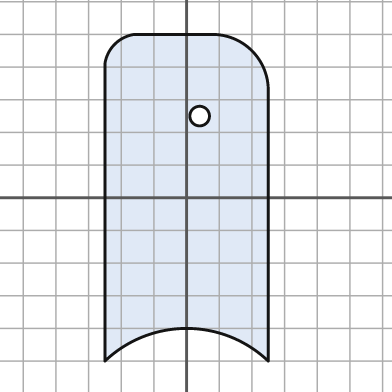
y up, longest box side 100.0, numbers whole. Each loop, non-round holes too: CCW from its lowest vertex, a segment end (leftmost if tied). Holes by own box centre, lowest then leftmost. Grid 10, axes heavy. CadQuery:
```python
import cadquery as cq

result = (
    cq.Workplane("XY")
    .moveTo(-25.0, -50.0)
    .threePointArc((0.0, -40.0), (25.0, -50.0))
    .lineTo(25.0, 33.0)
    .threePointArc((20.0, 45.0), (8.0, 50.0))
    .lineTo(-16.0, 50.0)
    .threePointArc((-22.0, 47.0), (-25.0, 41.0))
    .close()
    .moveTo(4.0, 25.0)
    .circle(3.0)
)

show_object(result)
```